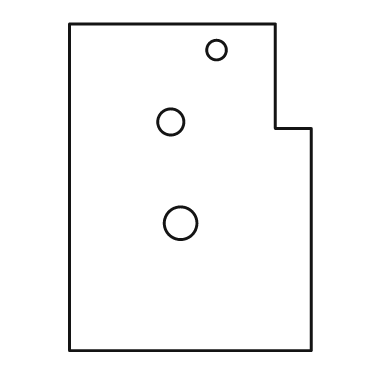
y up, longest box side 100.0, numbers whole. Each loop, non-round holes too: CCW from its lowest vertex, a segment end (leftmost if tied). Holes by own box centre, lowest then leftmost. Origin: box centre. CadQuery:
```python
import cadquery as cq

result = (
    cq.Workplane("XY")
    .moveTo(-37.0, -50.0)
    .lineTo(37.0, -50.0)
    .lineTo(37.0, 18.0)
    .lineTo(26.0, 18.0)
    .lineTo(26.0, 50.0)
    .lineTo(-37.0, 50.0)
    .close()
    .moveTo(-3.0, -11.0)
    .circle(5.0)
    .moveTo(-6.0, 20.0)
    .circle(4.0)
    .moveTo(8.0, 42.0)
    .circle(3.0)
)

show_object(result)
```